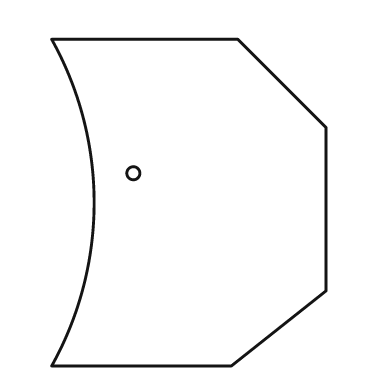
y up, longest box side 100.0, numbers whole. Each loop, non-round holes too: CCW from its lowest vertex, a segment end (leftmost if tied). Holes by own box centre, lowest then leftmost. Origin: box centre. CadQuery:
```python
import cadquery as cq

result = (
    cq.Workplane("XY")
    .moveTo(-42.0, -50.0)
    .lineTo(13.0, -50.0)
    .lineTo(42.0, -27.0)
    .lineTo(42.0, 23.0)
    .lineTo(15.0, 50.0)
    .lineTo(-42.0, 50.0)
    .threePointArc((-29.0, 0.0), (-42.0, -50.0))
    .close()
    .moveTo(-17.0, 9.0)
    .circle(2.0)
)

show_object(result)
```